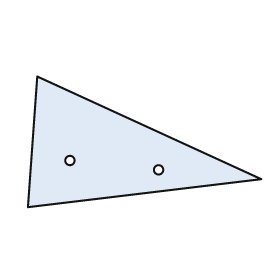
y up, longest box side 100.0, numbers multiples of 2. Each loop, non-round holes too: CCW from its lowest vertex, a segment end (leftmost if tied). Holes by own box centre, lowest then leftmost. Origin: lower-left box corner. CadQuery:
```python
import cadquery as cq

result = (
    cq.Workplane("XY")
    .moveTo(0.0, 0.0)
    .lineTo(100.0, 12.0)
    .lineTo(4.0, 56.0)
    .close()
    .moveTo(56.0, 16.0)
    .circle(2.0)
    .moveTo(18.0, 20.0)
    .circle(2.0)
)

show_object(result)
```